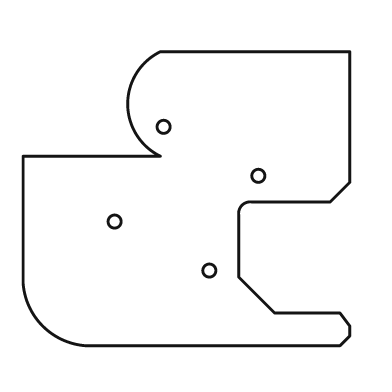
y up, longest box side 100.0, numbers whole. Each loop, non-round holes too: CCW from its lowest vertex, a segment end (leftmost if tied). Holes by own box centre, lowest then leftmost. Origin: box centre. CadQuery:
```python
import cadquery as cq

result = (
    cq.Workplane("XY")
    .moveTo(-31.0, -45.0)
    .lineTo(47.0, -45.0)
    .lineTo(50.0, -42.0)
    .lineTo(50.0, -39.0)
    .lineTo(47.0, -35.0)
    .lineTo(27.0, -35.0)
    .lineTo(16.0, -24.0)
    .lineTo(16.0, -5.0)
    .threePointArc((17.0, -2.0), (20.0, -1.0))
    .lineTo(44.0, -1.0)
    .lineTo(50.0, 5.0)
    .lineTo(50.0, 45.0)
    .lineTo(-8.0, 45.0)
    .threePointArc((-18.0, 29.0), (-8.0, 13.0))
    .lineTo(-50.0, 13.0)
    .lineTo(-50.0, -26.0)
    .threePointArc((-44.0, -39.0), (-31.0, -45.0))
    .close()
    .moveTo(7.0, -22.0)
    .circle(2.0)
    .moveTo(-22.0, -7.0)
    .circle(2.0)
    .moveTo(22.0, 7.0)
    .circle(2.0)
    .moveTo(-7.0, 22.0)
    .circle(2.0)
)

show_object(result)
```